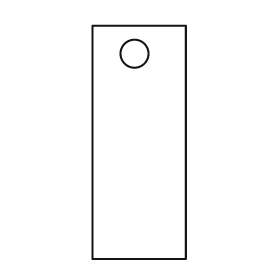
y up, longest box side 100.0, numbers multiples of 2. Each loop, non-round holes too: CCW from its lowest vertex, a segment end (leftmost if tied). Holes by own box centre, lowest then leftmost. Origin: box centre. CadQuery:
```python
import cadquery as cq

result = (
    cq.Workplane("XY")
    .moveTo(-20.0, -50.0)
    .lineTo(20.0, -50.0)
    .lineTo(20.0, 50.0)
    .lineTo(-20.0, 50.0)
    .close()
    .moveTo(-2.0, 38.0)
    .circle(6.0)
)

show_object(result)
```